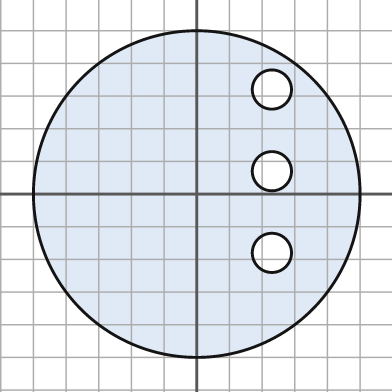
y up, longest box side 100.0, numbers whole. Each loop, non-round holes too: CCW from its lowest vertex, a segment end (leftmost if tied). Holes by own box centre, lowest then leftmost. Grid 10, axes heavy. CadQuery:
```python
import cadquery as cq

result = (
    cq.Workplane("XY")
    .moveTo(0.0, 0.0)
    .circle(50.0)
    .moveTo(23.0, -18.0)
    .circle(6.0)
    .moveTo(23.0, 7.0)
    .circle(6.0)
    .moveTo(23.0, 32.0)
    .circle(6.0)
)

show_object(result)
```